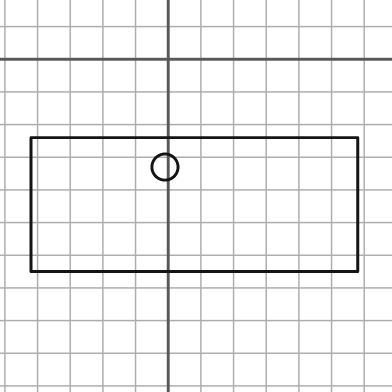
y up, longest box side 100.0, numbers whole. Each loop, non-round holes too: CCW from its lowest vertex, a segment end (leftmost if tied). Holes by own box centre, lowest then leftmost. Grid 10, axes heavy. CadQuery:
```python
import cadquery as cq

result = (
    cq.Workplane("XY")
    .moveTo(-42.0, -65.0)
    .lineTo(58.0, -65.0)
    .lineTo(58.0, -24.0)
    .lineTo(-42.0, -24.0)
    .close()
    .moveTo(-1.0, -33.0)
    .circle(4.0)
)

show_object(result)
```